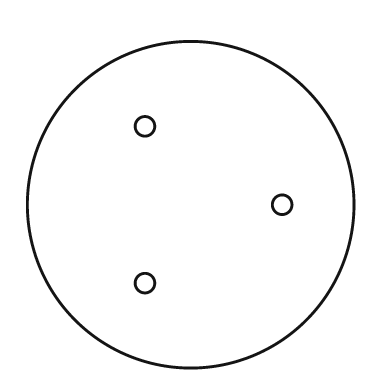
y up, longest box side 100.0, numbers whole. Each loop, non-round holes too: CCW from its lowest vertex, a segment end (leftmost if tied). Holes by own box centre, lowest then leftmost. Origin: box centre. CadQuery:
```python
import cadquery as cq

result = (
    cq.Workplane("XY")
    .moveTo(0.0, 0.0)
    .circle(50.0)
    .moveTo(-14.0, -24.0)
    .circle(3.0)
    .moveTo(28.0, 0.0)
    .circle(3.0)
    .moveTo(-14.0, 24.0)
    .circle(3.0)
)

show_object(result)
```